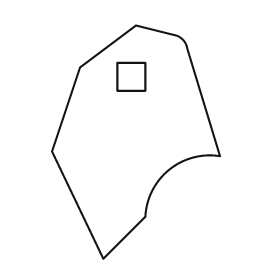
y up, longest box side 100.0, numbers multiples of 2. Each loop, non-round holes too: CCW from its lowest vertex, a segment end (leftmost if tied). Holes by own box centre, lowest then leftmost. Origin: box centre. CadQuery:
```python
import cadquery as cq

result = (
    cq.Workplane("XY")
    .moveTo(-14.0, -50.0)
    .lineTo(4.0, -32.0)
    .threePointArc((14.0, -12.0), (36.0, -6.0))
    .lineTo(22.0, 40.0)
    .threePointArc((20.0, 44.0), (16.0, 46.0))
    .lineTo(0.0, 50.0)
    .lineTo(-24.0, 32.0)
    .lineTo(-36.0, -4.0)
    .close()
    .moveTo(-8.0, 22.0)
    .lineTo(4.0, 22.0)
    .lineTo(4.0, 34.0)
    .lineTo(-8.0, 34.0)
    .close()
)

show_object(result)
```